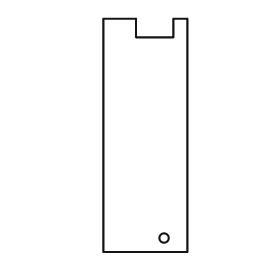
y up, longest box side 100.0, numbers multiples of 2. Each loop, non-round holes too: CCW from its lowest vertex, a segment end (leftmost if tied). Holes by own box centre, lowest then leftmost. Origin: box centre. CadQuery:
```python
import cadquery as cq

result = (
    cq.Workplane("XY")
    .moveTo(-18.0, -50.0)
    .lineTo(18.0, -50.0)
    .lineTo(18.0, 50.0)
    .lineTo(12.0, 50.0)
    .lineTo(12.0, 42.0)
    .lineTo(-4.0, 42.0)
    .lineTo(-4.0, 50.0)
    .lineTo(-18.0, 50.0)
    .close()
    .moveTo(8.0, -44.0)
    .circle(2.0)
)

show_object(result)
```